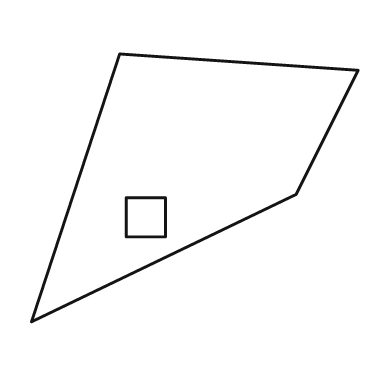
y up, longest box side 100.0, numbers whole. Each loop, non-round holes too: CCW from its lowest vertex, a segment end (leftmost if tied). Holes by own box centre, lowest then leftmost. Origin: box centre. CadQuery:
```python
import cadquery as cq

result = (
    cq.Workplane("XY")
    .moveTo(-50.0, -41.0)
    .lineTo(31.0, -2.0)
    .lineTo(50.0, 36.0)
    .lineTo(-23.0, 41.0)
    .close()
    .moveTo(-21.0, -15.0)
    .lineTo(-9.0, -15.0)
    .lineTo(-9.0, -3.0)
    .lineTo(-21.0, -3.0)
    .close()
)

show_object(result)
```